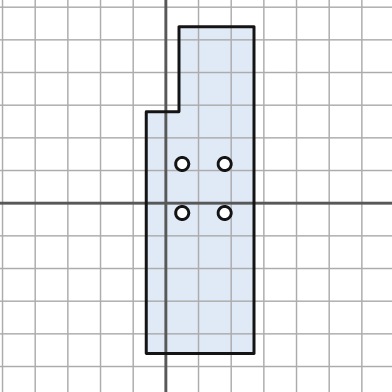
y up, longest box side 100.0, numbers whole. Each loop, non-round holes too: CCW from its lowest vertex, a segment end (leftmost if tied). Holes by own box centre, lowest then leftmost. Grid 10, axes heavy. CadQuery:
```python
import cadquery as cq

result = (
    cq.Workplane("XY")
    .moveTo(-6.0, -46.0)
    .lineTo(27.0, -46.0)
    .lineTo(27.0, 54.0)
    .lineTo(4.0, 54.0)
    .lineTo(4.0, 28.0)
    .lineTo(-6.0, 28.0)
    .close()
    .moveTo(5.0, -3.0)
    .circle(2.0)
    .moveTo(18.0, -3.0)
    .circle(2.0)
    .moveTo(5.0, 12.0)
    .circle(2.0)
    .moveTo(18.0, 12.0)
    .circle(2.0)
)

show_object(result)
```